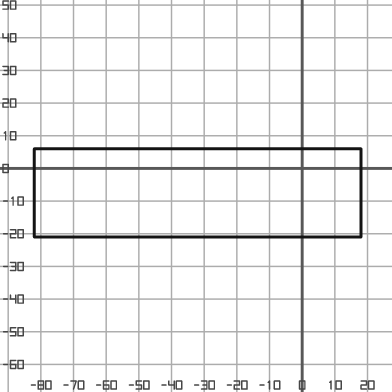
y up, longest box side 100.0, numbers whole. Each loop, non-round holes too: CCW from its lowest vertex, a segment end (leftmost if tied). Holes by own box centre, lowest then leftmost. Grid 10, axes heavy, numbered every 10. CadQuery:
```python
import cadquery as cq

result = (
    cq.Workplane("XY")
    .moveTo(-82.0, -21.0)
    .lineTo(18.0, -21.0)
    .lineTo(18.0, 6.0)
    .lineTo(-82.0, 6.0)
    .close()
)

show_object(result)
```